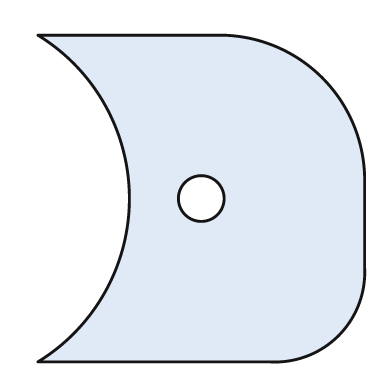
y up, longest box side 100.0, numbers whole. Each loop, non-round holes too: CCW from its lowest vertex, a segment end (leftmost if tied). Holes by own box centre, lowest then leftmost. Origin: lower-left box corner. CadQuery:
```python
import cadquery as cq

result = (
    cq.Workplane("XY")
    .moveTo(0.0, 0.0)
    .lineTo(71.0, 0.0)
    .threePointArc((92.0, 8.0), (100.0, 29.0))
    .lineTo(100.0, 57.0)
    .threePointArc((87.0, 87.0), (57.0, 100.0))
    .lineTo(0.0, 100.0)
    .threePointArc((28.0, 50.0), (0.0, 0.0))
    .close()
    .moveTo(50.0, 50.0)
    .circle(7.0)
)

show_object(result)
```